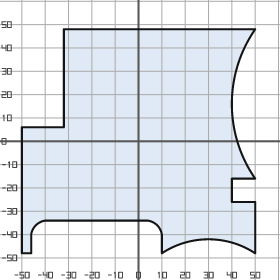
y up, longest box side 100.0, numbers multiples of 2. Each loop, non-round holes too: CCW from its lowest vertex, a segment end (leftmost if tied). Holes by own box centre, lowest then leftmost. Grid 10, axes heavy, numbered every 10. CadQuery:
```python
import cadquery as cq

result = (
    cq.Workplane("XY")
    .moveTo(-50.0, -48.0)
    .lineTo(-46.0, -48.0)
    .lineTo(-46.0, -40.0)
    .threePointArc((-44.0, -36.0), (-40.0, -34.0))
    .lineTo(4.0, -34.0)
    .threePointArc((8.0, -36.0), (10.0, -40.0))
    .lineTo(10.0, -48.0)
    .threePointArc((30.0, -42.0), (50.0, -48.0))
    .lineTo(50.0, -26.0)
    .lineTo(40.0, -26.0)
    .lineTo(40.0, -16.0)
    .lineTo(50.0, -16.0)
    .threePointArc((40.0, 16.0), (50.0, 48.0))
    .lineTo(-32.0, 48.0)
    .lineTo(-32.0, 6.0)
    .lineTo(-50.0, 6.0)
    .close()
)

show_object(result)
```